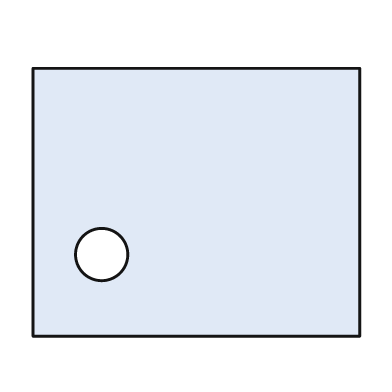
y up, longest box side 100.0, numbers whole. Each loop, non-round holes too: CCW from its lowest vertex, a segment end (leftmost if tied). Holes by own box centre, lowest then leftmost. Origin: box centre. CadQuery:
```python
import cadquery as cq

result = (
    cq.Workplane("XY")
    .moveTo(-50.0, -41.0)
    .lineTo(50.0, -41.0)
    .lineTo(50.0, 41.0)
    .lineTo(-50.0, 41.0)
    .close()
    .moveTo(-29.0, -16.0)
    .circle(8.0)
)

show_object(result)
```